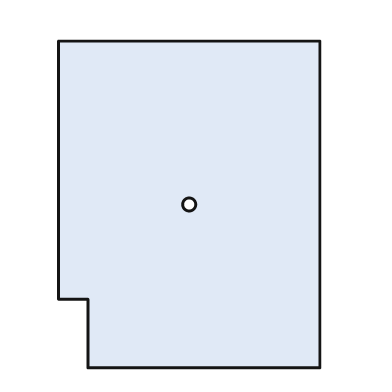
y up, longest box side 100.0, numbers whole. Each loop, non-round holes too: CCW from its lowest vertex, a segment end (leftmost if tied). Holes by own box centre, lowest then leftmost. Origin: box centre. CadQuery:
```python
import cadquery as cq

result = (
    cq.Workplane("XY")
    .moveTo(-31.0, -50.0)
    .lineTo(40.0, -50.0)
    .lineTo(40.0, 50.0)
    .lineTo(-40.0, 50.0)
    .lineTo(-40.0, -29.0)
    .lineTo(-31.0, -29.0)
    .close()
    .moveTo(0.0, 0.0)
    .circle(2.0)
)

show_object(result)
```